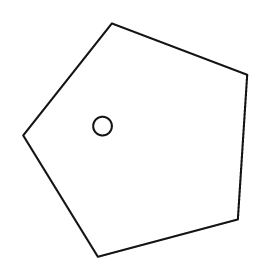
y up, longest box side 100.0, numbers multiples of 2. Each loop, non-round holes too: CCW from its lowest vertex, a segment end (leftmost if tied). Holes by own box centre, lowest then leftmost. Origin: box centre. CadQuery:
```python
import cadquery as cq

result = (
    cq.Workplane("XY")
    .moveTo(-16.0, -50.0)
    .lineTo(44.0, -34.0)
    .lineTo(48.0, 28.0)
    .lineTo(-10.0, 50.0)
    .lineTo(-48.0, 2.0)
    .close()
    .moveTo(-14.0, 6.0)
    .circle(4.0)
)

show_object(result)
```